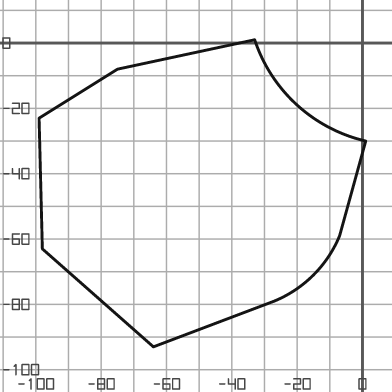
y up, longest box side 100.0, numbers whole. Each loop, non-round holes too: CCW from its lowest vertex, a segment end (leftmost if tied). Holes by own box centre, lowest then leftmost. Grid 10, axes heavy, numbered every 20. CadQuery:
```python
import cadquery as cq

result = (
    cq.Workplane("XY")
    .moveTo(-64.0, -93.0)
    .lineTo(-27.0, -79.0)
    .threePointArc((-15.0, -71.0), (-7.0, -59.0))
    .lineTo(1.0, -30.0)
    .threePointArc((-20.0, -19.0), (-33.0, 1.0))
    .lineTo(-75.0, -8.0)
    .lineTo(-99.0, -23.0)
    .lineTo(-98.0, -63.0)
    .close()
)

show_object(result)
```